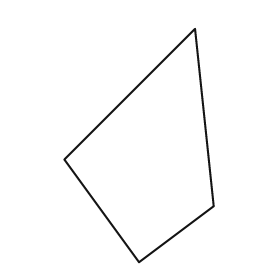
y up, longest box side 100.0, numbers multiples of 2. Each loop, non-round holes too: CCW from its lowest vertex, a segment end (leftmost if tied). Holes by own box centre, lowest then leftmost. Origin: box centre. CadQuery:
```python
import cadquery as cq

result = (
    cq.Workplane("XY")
    .moveTo(0.0, -50.0)
    .lineTo(32.0, -26.0)
    .lineTo(24.0, 50.0)
    .lineTo(-32.0, -6.0)
    .close()
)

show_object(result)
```